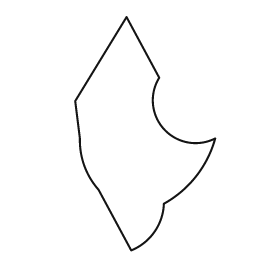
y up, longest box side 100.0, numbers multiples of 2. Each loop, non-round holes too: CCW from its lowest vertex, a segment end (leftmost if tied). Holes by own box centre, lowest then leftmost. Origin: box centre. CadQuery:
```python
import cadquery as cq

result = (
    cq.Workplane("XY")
    .moveTo(-6.0, -50.0)
    .threePointArc((4.0, -42.0), (8.0, -30.0))
    .threePointArc((22.0, -18.0), (30.0, -2.0))
    .threePointArc((8.0, 2.0), (6.0, 24.0))
    .lineTo(-8.0, 50.0)
    .lineTo(-30.0, 14.0)
    .lineTo(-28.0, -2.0)
    .threePointArc((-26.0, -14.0), (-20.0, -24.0))
    .close()
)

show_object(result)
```